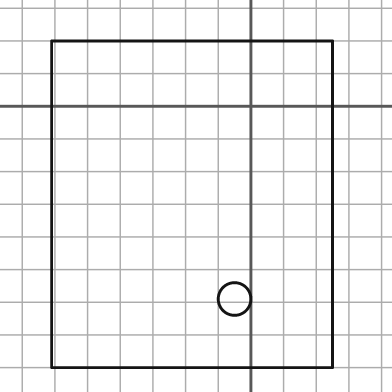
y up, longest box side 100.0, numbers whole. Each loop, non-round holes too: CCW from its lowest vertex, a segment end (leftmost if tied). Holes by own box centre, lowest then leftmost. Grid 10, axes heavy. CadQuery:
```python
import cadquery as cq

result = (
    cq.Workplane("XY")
    .moveTo(-61.0, -80.0)
    .lineTo(25.0, -80.0)
    .lineTo(25.0, 20.0)
    .lineTo(-61.0, 20.0)
    .close()
    .moveTo(-5.0, -59.0)
    .circle(5.0)
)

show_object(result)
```